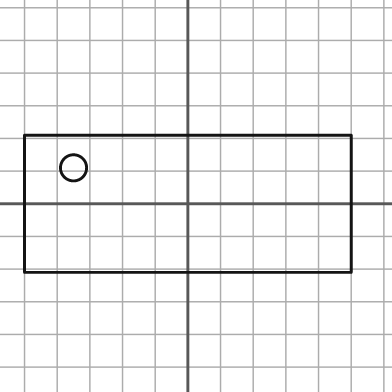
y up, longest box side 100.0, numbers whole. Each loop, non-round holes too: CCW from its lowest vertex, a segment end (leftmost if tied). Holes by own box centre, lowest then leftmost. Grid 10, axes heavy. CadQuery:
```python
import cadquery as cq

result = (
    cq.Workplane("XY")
    .moveTo(-50.0, -21.0)
    .lineTo(50.0, -21.0)
    .lineTo(50.0, 21.0)
    .lineTo(-50.0, 21.0)
    .close()
    .moveTo(-35.0, 11.0)
    .circle(4.0)
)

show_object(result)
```